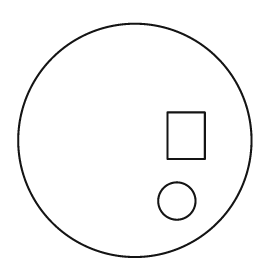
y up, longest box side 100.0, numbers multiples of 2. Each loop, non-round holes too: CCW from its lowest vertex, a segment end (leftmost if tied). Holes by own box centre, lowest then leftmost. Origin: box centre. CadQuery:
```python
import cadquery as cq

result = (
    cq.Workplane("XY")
    .moveTo(0.0, 0.0)
    .circle(50.0)
    .moveTo(18.0, -26.0)
    .circle(8.0)
    .moveTo(14.0, -8.0)
    .lineTo(30.0, -8.0)
    .lineTo(30.0, 12.0)
    .lineTo(14.0, 12.0)
    .close()
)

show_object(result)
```